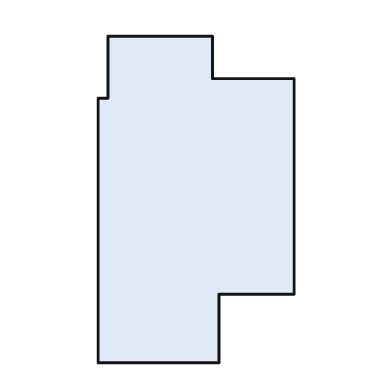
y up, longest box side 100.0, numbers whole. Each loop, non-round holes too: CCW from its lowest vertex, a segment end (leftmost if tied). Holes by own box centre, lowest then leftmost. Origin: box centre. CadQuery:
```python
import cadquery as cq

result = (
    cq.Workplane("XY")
    .moveTo(-30.0, -50.0)
    .lineTo(7.0, -50.0)
    .lineTo(7.0, -29.0)
    .lineTo(30.0, -29.0)
    .lineTo(30.0, 37.0)
    .lineTo(5.0, 37.0)
    .lineTo(5.0, 50.0)
    .lineTo(-27.0, 50.0)
    .lineTo(-27.0, 31.0)
    .lineTo(-30.0, 31.0)
    .close()
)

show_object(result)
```